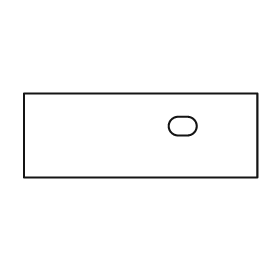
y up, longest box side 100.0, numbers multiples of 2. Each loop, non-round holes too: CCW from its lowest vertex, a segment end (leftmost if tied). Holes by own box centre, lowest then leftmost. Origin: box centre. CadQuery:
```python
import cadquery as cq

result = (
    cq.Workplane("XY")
    .moveTo(-50.0, -18.0)
    .lineTo(50.0, -18.0)
    .lineTo(50.0, 18.0)
    .lineTo(-50.0, 18.0)
    .close()
    .moveTo(16.0, 0.0)
    .lineTo(20.0, 0.0)
    .threePointArc((24.0, 4.0), (20.0, 8.0))
    .lineTo(16.0, 8.0)
    .threePointArc((12.0, 4.0), (16.0, 0.0))
    .close()
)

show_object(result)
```